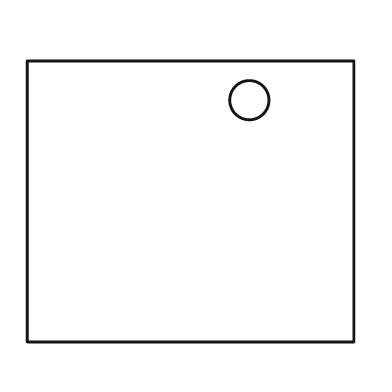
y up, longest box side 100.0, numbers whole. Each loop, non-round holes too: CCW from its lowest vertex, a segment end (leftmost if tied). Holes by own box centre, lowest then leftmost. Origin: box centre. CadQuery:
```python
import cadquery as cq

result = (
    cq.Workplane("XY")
    .moveTo(-50.0, -43.0)
    .lineTo(50.0, -43.0)
    .lineTo(50.0, 43.0)
    .lineTo(-50.0, 43.0)
    .close()
    .moveTo(18.0, 31.0)
    .circle(6.0)
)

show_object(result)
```